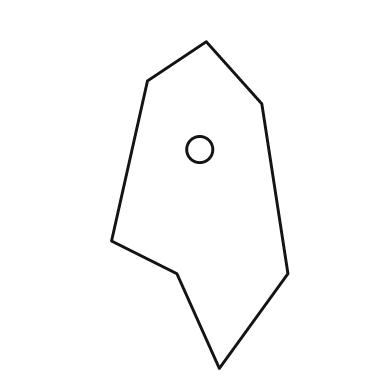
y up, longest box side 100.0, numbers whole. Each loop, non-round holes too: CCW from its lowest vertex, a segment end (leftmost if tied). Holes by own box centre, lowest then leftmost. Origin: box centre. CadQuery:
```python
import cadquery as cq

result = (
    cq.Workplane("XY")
    .moveTo(6.0, -50.0)
    .lineTo(27.0, -21.0)
    .lineTo(19.0, 31.0)
    .lineTo(2.0, 50.0)
    .lineTo(-16.0, 38.0)
    .lineTo(-27.0, -11.0)
    .lineTo(-7.0, -21.0)
    .close()
    .moveTo(0.0, 17.0)
    .circle(4.0)
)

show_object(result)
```